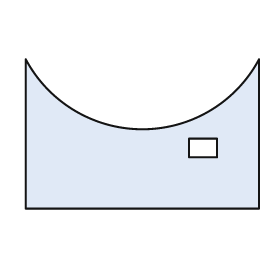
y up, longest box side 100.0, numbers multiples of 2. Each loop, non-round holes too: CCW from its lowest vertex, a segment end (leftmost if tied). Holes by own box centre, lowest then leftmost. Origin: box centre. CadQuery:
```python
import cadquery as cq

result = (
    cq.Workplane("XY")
    .moveTo(-50.0, -32.0)
    .lineTo(50.0, -32.0)
    .lineTo(50.0, 32.0)
    .threePointArc((0.0, 2.0), (-50.0, 32.0))
    .close()
    .moveTo(20.0, -10.0)
    .lineTo(32.0, -10.0)
    .lineTo(32.0, -2.0)
    .lineTo(20.0, -2.0)
    .close()
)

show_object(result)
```